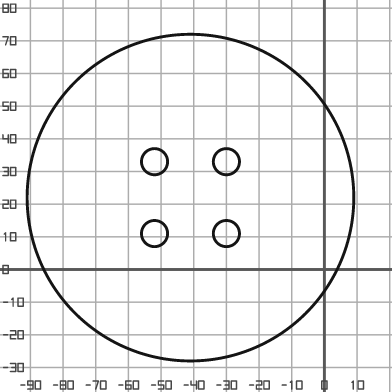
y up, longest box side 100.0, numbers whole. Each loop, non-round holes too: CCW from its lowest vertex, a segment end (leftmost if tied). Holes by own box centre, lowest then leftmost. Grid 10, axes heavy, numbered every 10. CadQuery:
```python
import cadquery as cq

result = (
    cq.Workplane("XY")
    .moveTo(-41.0, 22.0)
    .circle(50.0)
    .moveTo(-52.0, 11.0)
    .circle(4.0)
    .moveTo(-30.0, 11.0)
    .circle(4.0)
    .moveTo(-52.0, 33.0)
    .circle(4.0)
    .moveTo(-30.0, 33.0)
    .circle(4.0)
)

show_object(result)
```